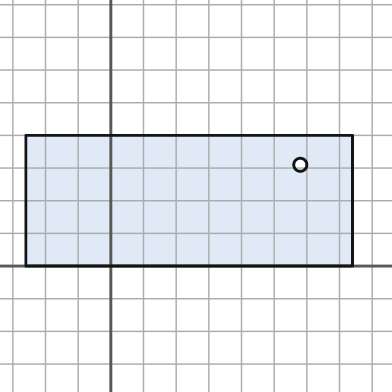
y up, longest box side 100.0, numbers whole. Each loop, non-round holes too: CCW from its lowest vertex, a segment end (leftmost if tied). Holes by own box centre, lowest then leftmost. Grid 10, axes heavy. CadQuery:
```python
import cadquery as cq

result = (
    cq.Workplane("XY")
    .moveTo(-26.0, 0.0)
    .lineTo(74.0, 0.0)
    .lineTo(74.0, 40.0)
    .lineTo(-26.0, 40.0)
    .close()
    .moveTo(58.0, 31.0)
    .circle(2.0)
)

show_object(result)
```